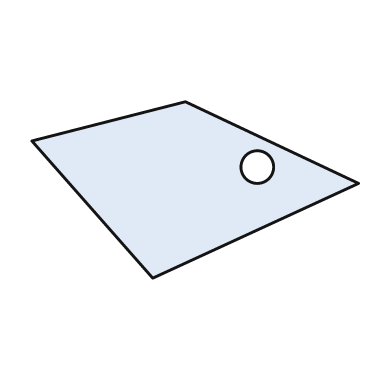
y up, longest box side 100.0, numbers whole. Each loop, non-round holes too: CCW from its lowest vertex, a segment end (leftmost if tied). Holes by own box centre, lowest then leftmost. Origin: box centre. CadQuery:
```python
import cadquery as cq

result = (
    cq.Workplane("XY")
    .moveTo(-13.0, -27.0)
    .lineTo(50.0, 2.0)
    .lineTo(-3.0, 27.0)
    .lineTo(-50.0, 15.0)
    .close()
    .moveTo(19.0, 7.0)
    .circle(5.0)
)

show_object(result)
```